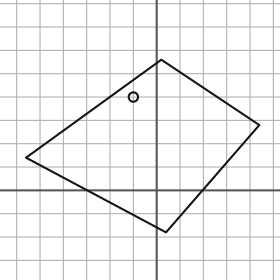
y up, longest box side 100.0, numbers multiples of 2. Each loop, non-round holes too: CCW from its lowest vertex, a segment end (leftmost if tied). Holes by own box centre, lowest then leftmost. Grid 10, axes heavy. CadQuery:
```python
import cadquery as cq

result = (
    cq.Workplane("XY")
    .moveTo(4.0, -18.0)
    .lineTo(44.0, 28.0)
    .lineTo(2.0, 56.0)
    .lineTo(-56.0, 14.0)
    .close()
    .moveTo(-10.0, 40.0)
    .circle(2.0)
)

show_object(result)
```